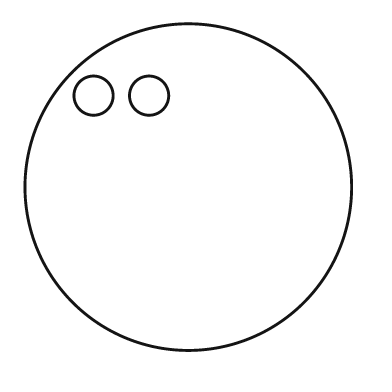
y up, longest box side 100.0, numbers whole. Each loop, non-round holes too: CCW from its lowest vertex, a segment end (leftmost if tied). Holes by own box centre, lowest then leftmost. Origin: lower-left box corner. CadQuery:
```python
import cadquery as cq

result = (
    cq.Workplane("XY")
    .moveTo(50.0, 50.0)
    .circle(50.0)
    .moveTo(21.0, 78.0)
    .circle(6.0)
    .moveTo(38.0, 78.0)
    .circle(6.0)
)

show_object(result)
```